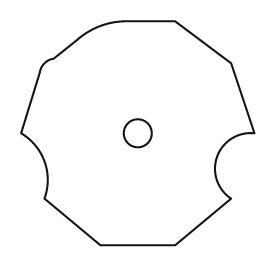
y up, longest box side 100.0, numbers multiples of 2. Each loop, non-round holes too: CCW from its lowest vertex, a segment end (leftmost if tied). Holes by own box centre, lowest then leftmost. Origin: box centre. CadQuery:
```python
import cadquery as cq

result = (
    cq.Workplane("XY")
    .moveTo(-16.0, -48.0)
    .lineTo(16.0, -48.0)
    .lineTo(40.0, -28.0)
    .threePointArc((34.0, -10.0), (50.0, 0.0))
    .lineTo(40.0, 30.0)
    .lineTo(16.0, 48.0)
    .lineTo(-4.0, 48.0)
    .threePointArc((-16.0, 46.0), (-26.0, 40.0))
    .lineTo(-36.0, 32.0)
    .threePointArc((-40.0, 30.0), (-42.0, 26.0))
    .lineTo(-50.0, 0.0)
    .threePointArc((-40.0, -12.0), (-40.0, -28.0))
    .close()
    .moveTo(0.0, 0.0)
    .circle(6.0)
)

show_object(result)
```